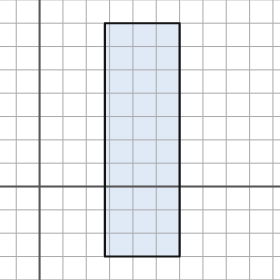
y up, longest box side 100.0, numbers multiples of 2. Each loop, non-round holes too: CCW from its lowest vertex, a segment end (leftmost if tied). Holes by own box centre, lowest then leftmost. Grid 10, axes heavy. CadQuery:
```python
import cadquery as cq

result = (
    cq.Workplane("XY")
    .moveTo(28.0, -30.0)
    .lineTo(60.0, -30.0)
    .lineTo(60.0, 70.0)
    .lineTo(28.0, 70.0)
    .close()
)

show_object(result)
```